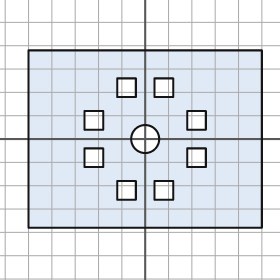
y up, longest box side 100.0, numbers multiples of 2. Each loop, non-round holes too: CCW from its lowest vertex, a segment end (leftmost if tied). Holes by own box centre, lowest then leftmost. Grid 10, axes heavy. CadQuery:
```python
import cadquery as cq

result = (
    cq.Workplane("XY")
    .moveTo(-50.0, -38.0)
    .lineTo(50.0, -38.0)
    .lineTo(50.0, 38.0)
    .lineTo(-50.0, 38.0)
    .close()
    .moveTo(-12.0, -26.0)
    .lineTo(-4.0, -26.0)
    .lineTo(-4.0, -18.0)
    .lineTo(-12.0, -18.0)
    .close()
    .moveTo(4.0, -26.0)
    .lineTo(12.0, -26.0)
    .lineTo(12.0, -18.0)
    .lineTo(4.0, -18.0)
    .close()
    .moveTo(-26.0, -12.0)
    .lineTo(-18.0, -12.0)
    .lineTo(-18.0, -4.0)
    .lineTo(-26.0, -4.0)
    .close()
    .moveTo(18.0, -12.0)
    .lineTo(26.0, -12.0)
    .lineTo(26.0, -4.0)
    .lineTo(18.0, -4.0)
    .close()
    .moveTo(0.0, 0.0)
    .circle(6.0)
    .moveTo(-26.0, 4.0)
    .lineTo(-18.0, 4.0)
    .lineTo(-18.0, 12.0)
    .lineTo(-26.0, 12.0)
    .close()
    .moveTo(18.0, 4.0)
    .lineTo(26.0, 4.0)
    .lineTo(26.0, 12.0)
    .lineTo(18.0, 12.0)
    .close()
    .moveTo(-12.0, 18.0)
    .lineTo(-4.0, 18.0)
    .lineTo(-4.0, 26.0)
    .lineTo(-12.0, 26.0)
    .close()
    .moveTo(4.0, 18.0)
    .lineTo(12.0, 18.0)
    .lineTo(12.0, 26.0)
    .lineTo(4.0, 26.0)
    .close()
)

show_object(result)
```